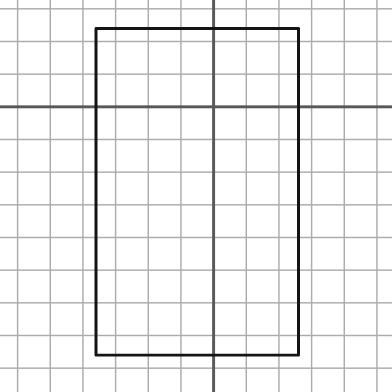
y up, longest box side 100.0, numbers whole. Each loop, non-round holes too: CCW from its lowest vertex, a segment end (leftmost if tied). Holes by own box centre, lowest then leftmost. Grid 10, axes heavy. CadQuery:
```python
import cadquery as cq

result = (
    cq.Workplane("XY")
    .moveTo(-36.0, -76.0)
    .lineTo(26.0, -76.0)
    .lineTo(26.0, 24.0)
    .lineTo(-36.0, 24.0)
    .close()
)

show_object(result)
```